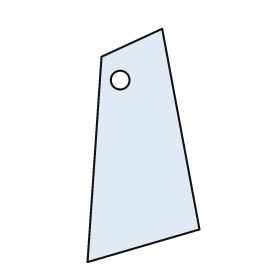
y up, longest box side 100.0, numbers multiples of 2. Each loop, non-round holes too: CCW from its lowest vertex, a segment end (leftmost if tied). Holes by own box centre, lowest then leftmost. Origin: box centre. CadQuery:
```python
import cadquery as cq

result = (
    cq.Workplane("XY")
    .moveTo(-24.0, -50.0)
    .lineTo(24.0, -36.0)
    .lineTo(8.0, 50.0)
    .lineTo(-18.0, 38.0)
    .close()
    .moveTo(-10.0, 28.0)
    .circle(4.0)
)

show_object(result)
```